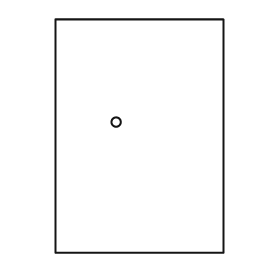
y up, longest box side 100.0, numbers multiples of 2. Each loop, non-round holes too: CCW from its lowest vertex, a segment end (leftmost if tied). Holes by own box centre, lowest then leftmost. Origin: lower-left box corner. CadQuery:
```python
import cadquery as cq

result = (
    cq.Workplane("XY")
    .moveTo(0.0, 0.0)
    .lineTo(72.0, 0.0)
    .lineTo(72.0, 100.0)
    .lineTo(0.0, 100.0)
    .close()
    .moveTo(26.0, 56.0)
    .circle(2.0)
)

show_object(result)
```